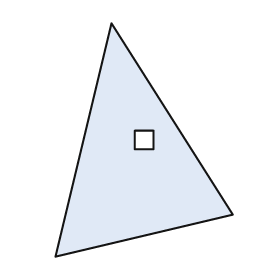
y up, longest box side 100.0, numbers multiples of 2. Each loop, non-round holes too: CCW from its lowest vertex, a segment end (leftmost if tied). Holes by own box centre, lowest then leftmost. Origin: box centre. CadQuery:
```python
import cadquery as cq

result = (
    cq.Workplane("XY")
    .moveTo(-38.0, -50.0)
    .lineTo(38.0, -32.0)
    .lineTo(-14.0, 50.0)
    .close()
    .moveTo(-4.0, -4.0)
    .lineTo(4.0, -4.0)
    .lineTo(4.0, 4.0)
    .lineTo(-4.0, 4.0)
    .close()
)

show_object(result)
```